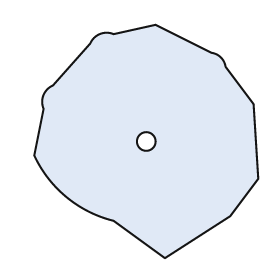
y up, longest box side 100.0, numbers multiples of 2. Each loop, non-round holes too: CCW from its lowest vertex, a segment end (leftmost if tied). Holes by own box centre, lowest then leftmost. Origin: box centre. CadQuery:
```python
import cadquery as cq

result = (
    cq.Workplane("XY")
    .moveTo(8.0, -50.0)
    .lineTo(36.0, -32.0)
    .lineTo(48.0, -16.0)
    .lineTo(46.0, 16.0)
    .lineTo(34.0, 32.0)
    .threePointArc((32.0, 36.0), (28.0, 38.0))
    .lineTo(4.0, 50.0)
    .lineTo(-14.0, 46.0)
    .threePointArc((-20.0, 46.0), (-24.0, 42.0))
    .lineTo(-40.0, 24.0)
    .threePointArc((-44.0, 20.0), (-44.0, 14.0))
    .lineTo(-48.0, -6.0)
    .threePointArc((-34.0, -24.0), (-14.0, -34.0))
    .close()
    .moveTo(0.0, 0.0)
    .circle(4.0)
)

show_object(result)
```